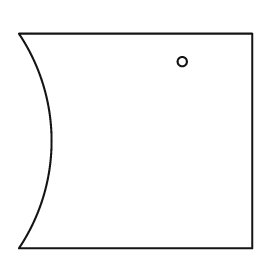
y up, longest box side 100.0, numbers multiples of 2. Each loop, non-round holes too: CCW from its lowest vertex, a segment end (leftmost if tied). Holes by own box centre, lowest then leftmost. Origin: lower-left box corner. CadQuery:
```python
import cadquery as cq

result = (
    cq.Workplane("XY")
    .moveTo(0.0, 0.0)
    .lineTo(100.0, 0.0)
    .lineTo(100.0, 92.0)
    .lineTo(0.0, 92.0)
    .threePointArc((14.0, 46.0), (0.0, 0.0))
    .close()
    .moveTo(70.0, 80.0)
    .circle(2.0)
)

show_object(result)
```